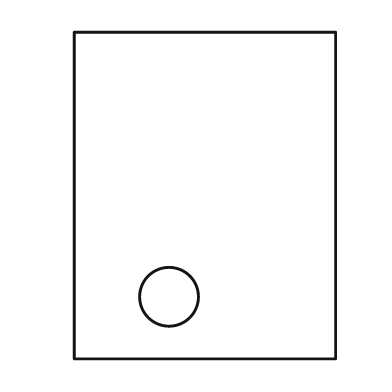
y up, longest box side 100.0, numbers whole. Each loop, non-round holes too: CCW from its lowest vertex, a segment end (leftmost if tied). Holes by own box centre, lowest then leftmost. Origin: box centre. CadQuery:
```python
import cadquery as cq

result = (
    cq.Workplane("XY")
    .moveTo(-40.0, -50.0)
    .lineTo(40.0, -50.0)
    .lineTo(40.0, 50.0)
    .lineTo(-40.0, 50.0)
    .close()
    .moveTo(-11.0, -31.0)
    .circle(9.0)
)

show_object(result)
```